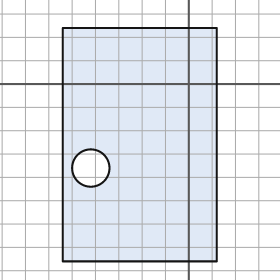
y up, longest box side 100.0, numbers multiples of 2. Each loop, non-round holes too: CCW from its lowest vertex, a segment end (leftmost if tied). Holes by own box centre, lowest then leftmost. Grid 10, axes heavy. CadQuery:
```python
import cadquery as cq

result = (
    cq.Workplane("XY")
    .moveTo(-54.0, -76.0)
    .lineTo(12.0, -76.0)
    .lineTo(12.0, 24.0)
    .lineTo(-54.0, 24.0)
    .close()
    .moveTo(-42.0, -36.0)
    .circle(8.0)
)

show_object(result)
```